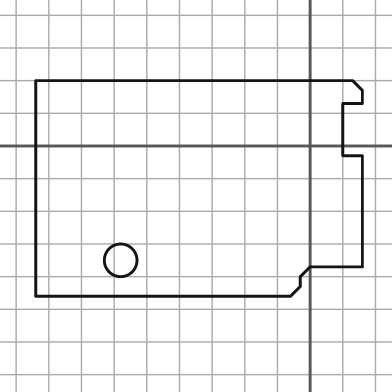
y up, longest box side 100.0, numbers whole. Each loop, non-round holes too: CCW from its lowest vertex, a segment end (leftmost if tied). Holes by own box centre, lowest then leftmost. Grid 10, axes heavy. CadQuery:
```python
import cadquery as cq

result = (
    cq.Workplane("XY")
    .moveTo(-84.0, -46.0)
    .lineTo(-6.0, -46.0)
    .lineTo(-3.0, -43.0)
    .lineTo(-3.0, -40.0)
    .lineTo(0.0, -37.0)
    .lineTo(16.0, -37.0)
    .lineTo(16.0, -3.0)
    .lineTo(10.0, -3.0)
    .lineTo(10.0, 13.0)
    .lineTo(16.0, 13.0)
    .lineTo(16.0, 17.0)
    .lineTo(13.0, 20.0)
    .lineTo(-84.0, 20.0)
    .close()
    .moveTo(-58.0, -35.0)
    .circle(5.0)
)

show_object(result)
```